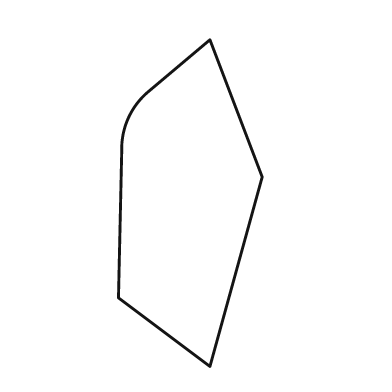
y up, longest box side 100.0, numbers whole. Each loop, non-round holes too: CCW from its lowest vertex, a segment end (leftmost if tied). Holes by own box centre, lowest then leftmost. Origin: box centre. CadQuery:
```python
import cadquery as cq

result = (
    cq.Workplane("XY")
    .moveTo(6.0, -50.0)
    .lineTo(22.0, 8.0)
    .lineTo(6.0, 50.0)
    .lineTo(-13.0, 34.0)
    .threePointArc((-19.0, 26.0), (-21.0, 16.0))
    .lineTo(-22.0, -29.0)
    .close()
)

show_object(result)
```